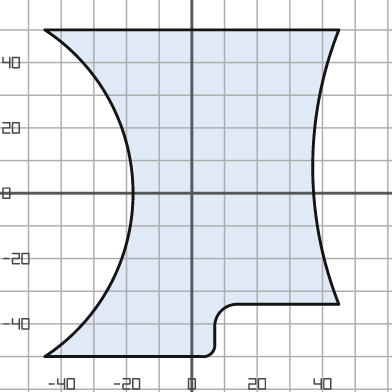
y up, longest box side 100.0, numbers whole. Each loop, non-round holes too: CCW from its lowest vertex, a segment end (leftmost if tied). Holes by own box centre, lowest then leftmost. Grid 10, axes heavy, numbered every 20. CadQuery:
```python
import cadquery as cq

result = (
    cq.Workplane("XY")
    .moveTo(-45.0, -50.0)
    .lineTo(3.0, -50.0)
    .threePointArc((6.0, -49.0), (7.0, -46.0))
    .lineTo(7.0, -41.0)
    .threePointArc((9.0, -36.0), (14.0, -34.0))
    .lineTo(45.0, -34.0)
    .threePointArc((37.0, 8.0), (45.0, 50.0))
    .lineTo(-45.0, 50.0)
    .threePointArc((-18.0, 0.0), (-45.0, -50.0))
    .close()
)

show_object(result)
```